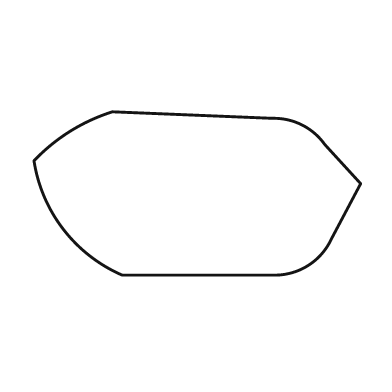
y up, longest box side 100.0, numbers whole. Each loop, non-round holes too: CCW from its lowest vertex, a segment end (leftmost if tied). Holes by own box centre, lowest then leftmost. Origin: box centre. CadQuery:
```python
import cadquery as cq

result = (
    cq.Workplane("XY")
    .moveTo(-23.0, -25.0)
    .lineTo(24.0, -25.0)
    .threePointArc((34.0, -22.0), (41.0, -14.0))
    .lineTo(50.0, 3.0)
    .lineTo(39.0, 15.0)
    .threePointArc((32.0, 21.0), (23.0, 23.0))
    .lineTo(-26.0, 25.0)
    .threePointArc((-39.0, 19.0), (-50.0, 10.0))
    .threePointArc((-41.0, -11.0), (-23.0, -25.0))
    .close()
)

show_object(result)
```